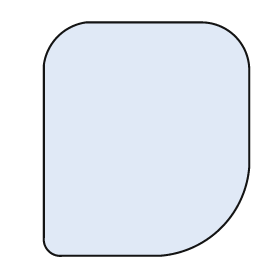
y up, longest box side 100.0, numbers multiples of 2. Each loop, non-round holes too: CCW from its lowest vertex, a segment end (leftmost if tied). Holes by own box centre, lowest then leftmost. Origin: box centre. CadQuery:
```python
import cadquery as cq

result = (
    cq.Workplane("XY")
    .moveTo(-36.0, -50.0)
    .lineTo(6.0, -50.0)
    .threePointArc((32.0, -38.0), (44.0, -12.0))
    .lineTo(44.0, 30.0)
    .threePointArc((38.0, 44.0), (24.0, 50.0))
    .lineTo(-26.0, 50.0)
    .threePointArc((-38.0, 44.0), (-44.0, 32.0))
    .lineTo(-44.0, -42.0)
    .threePointArc((-42.0, -48.0), (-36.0, -50.0))
    .close()
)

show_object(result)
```